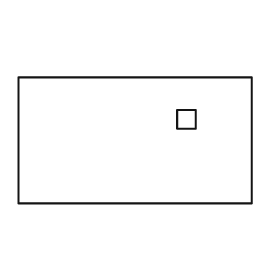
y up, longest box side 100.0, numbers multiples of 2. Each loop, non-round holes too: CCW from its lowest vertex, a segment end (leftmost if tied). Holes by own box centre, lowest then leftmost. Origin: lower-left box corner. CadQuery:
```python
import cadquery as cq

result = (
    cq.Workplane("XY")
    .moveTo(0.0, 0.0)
    .lineTo(100.0, 0.0)
    .lineTo(100.0, 54.0)
    .lineTo(0.0, 54.0)
    .close()
    .moveTo(68.0, 32.0)
    .lineTo(76.0, 32.0)
    .lineTo(76.0, 40.0)
    .lineTo(68.0, 40.0)
    .close()
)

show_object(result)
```